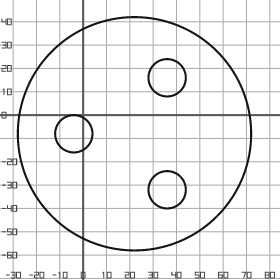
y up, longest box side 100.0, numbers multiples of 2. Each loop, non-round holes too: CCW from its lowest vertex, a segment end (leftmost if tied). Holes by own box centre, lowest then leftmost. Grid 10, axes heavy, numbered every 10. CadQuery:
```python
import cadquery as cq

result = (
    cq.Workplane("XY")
    .moveTo(22.0, -8.0)
    .circle(50.0)
    .moveTo(36.0, -32.0)
    .circle(8.0)
    .moveTo(-4.0, -8.0)
    .circle(8.0)
    .moveTo(36.0, 16.0)
    .circle(8.0)
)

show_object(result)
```